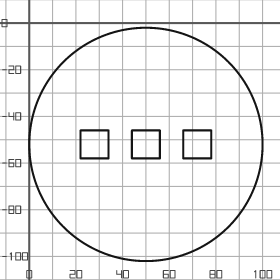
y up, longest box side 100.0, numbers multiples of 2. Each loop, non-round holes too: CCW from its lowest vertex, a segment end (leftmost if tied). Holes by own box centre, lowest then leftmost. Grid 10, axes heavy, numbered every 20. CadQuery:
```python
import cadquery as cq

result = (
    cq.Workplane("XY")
    .moveTo(50.0, -52.0)
    .circle(50.0)
    .moveTo(22.0, -58.0)
    .lineTo(34.0, -58.0)
    .lineTo(34.0, -46.0)
    .lineTo(22.0, -46.0)
    .close()
    .moveTo(44.0, -58.0)
    .lineTo(56.0, -58.0)
    .lineTo(56.0, -46.0)
    .lineTo(44.0, -46.0)
    .close()
    .moveTo(66.0, -58.0)
    .lineTo(78.0, -58.0)
    .lineTo(78.0, -46.0)
    .lineTo(66.0, -46.0)
    .close()
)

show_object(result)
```